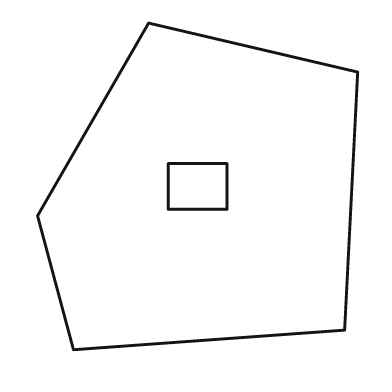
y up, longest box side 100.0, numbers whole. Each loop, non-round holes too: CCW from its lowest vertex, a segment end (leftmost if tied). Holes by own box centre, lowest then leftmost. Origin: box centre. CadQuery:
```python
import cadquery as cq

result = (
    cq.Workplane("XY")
    .moveTo(-38.0, -50.0)
    .lineTo(45.0, -44.0)
    .lineTo(49.0, 35.0)
    .lineTo(-15.0, 50.0)
    .lineTo(-49.0, -9.0)
    .close()
    .moveTo(-9.0, -7.0)
    .lineTo(9.0, -7.0)
    .lineTo(9.0, 7.0)
    .lineTo(-9.0, 7.0)
    .close()
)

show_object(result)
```